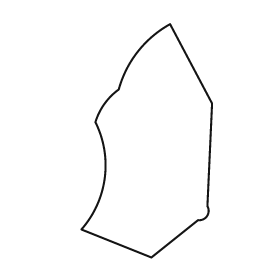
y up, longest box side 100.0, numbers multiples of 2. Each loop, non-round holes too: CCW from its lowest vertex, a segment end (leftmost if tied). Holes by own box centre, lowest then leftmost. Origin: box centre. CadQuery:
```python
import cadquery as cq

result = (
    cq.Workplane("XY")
    .moveTo(2.0, -50.0)
    .lineTo(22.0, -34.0)
    .threePointArc((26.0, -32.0), (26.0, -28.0))
    .lineTo(28.0, 16.0)
    .lineTo(10.0, 50.0)
    .threePointArc((-4.0, 38.0), (-12.0, 22.0))
    .threePointArc((-18.0, 16.0), (-22.0, 8.0))
    .threePointArc((-18.0, -16.0), (-28.0, -38.0))
    .close()
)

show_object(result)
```